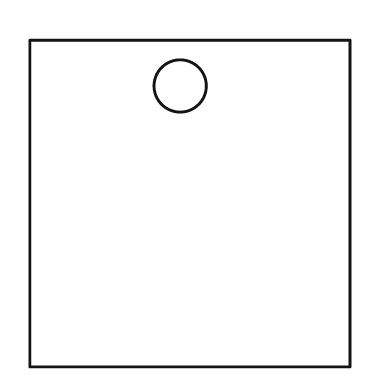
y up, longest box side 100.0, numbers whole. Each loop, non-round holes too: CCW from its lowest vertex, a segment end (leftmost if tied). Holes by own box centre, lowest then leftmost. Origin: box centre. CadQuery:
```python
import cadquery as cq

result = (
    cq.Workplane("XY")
    .moveTo(-49.0, -50.0)
    .lineTo(49.0, -50.0)
    .lineTo(49.0, 50.0)
    .lineTo(-49.0, 50.0)
    .close()
    .moveTo(-3.0, 36.0)
    .circle(8.0)
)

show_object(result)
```